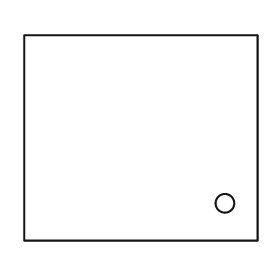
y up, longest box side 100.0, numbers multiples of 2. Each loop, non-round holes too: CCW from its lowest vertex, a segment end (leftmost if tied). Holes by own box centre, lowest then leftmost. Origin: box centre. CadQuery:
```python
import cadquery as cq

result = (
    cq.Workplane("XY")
    .moveTo(-50.0, -44.0)
    .lineTo(50.0, -44.0)
    .lineTo(50.0, 44.0)
    .lineTo(-50.0, 44.0)
    .close()
    .moveTo(36.0, -28.0)
    .circle(4.0)
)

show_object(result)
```